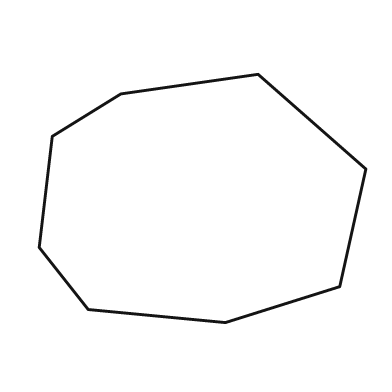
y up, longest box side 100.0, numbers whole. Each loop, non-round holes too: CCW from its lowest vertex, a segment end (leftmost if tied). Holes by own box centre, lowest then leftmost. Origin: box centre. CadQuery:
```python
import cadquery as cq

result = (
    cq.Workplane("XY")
    .moveTo(7.0, -38.0)
    .lineTo(42.0, -27.0)
    .lineTo(50.0, 9.0)
    .lineTo(17.0, 38.0)
    .lineTo(-25.0, 32.0)
    .lineTo(-46.0, 19.0)
    .lineTo(-50.0, -15.0)
    .lineTo(-35.0, -34.0)
    .close()
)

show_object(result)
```